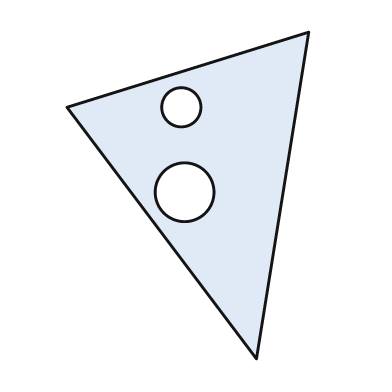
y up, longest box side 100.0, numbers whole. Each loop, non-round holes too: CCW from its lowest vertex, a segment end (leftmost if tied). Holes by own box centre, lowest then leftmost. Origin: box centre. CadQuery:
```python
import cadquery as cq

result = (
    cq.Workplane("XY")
    .moveTo(21.0, -50.0)
    .lineTo(37.0, 50.0)
    .lineTo(-37.0, 27.0)
    .close()
    .moveTo(-1.0, 1.0)
    .circle(9.0)
    .moveTo(-2.0, 27.0)
    .circle(6.0)
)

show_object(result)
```